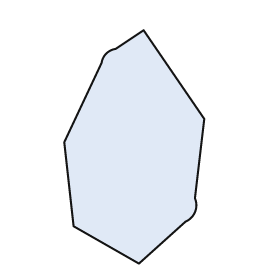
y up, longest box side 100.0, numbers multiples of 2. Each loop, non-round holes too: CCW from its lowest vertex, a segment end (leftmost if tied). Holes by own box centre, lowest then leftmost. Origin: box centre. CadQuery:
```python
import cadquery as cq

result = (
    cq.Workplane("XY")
    .moveTo(2.0, -50.0)
    .lineTo(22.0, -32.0)
    .threePointArc((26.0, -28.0), (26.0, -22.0))
    .lineTo(30.0, 12.0)
    .lineTo(4.0, 50.0)
    .lineTo(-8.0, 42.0)
    .threePointArc((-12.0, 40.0), (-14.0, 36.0))
    .lineTo(-30.0, 2.0)
    .lineTo(-26.0, -34.0)
    .close()
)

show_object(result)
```